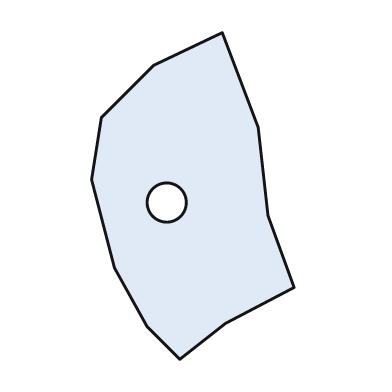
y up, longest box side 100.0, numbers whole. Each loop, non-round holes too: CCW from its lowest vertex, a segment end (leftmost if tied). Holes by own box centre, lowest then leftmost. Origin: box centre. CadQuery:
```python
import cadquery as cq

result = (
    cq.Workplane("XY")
    .moveTo(-4.0, -50.0)
    .lineTo(10.0, -39.0)
    .lineTo(31.0, -28.0)
    .lineTo(23.0, -6.0)
    .lineTo(20.0, 21.0)
    .lineTo(9.0, 50.0)
    .lineTo(-12.0, 40.0)
    .lineTo(-28.0, 24.0)
    .lineTo(-31.0, 5.0)
    .lineTo(-24.0, -22.0)
    .lineTo(-14.0, -40.0)
    .close()
    .moveTo(-8.0, -2.0)
    .circle(6.0)
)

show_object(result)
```